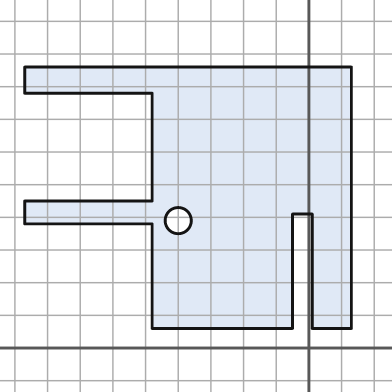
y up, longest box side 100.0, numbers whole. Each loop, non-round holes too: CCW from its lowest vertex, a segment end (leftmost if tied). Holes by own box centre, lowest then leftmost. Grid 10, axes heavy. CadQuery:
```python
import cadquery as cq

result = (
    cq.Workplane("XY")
    .moveTo(-48.0, 6.0)
    .lineTo(-5.0, 6.0)
    .lineTo(-5.0, 41.0)
    .lineTo(1.0, 41.0)
    .lineTo(1.0, 6.0)
    .lineTo(13.0, 6.0)
    .lineTo(13.0, 86.0)
    .lineTo(-87.0, 86.0)
    .lineTo(-87.0, 78.0)
    .lineTo(-48.0, 78.0)
    .lineTo(-48.0, 45.0)
    .lineTo(-87.0, 45.0)
    .lineTo(-87.0, 38.0)
    .lineTo(-48.0, 38.0)
    .close()
    .moveTo(-40.0, 39.0)
    .circle(4.0)
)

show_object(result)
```